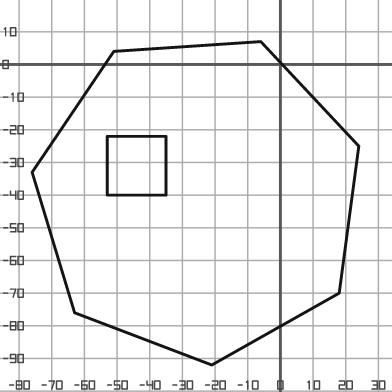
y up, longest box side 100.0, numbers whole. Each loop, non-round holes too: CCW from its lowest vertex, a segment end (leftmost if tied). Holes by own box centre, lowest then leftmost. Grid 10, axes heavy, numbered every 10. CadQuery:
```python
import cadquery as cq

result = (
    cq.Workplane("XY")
    .moveTo(-21.0, -92.0)
    .lineTo(18.0, -70.0)
    .lineTo(24.0, -25.0)
    .lineTo(-6.0, 7.0)
    .lineTo(-51.0, 4.0)
    .lineTo(-76.0, -33.0)
    .lineTo(-63.0, -76.0)
    .close()
    .moveTo(-53.0, -40.0)
    .lineTo(-35.0, -40.0)
    .lineTo(-35.0, -22.0)
    .lineTo(-53.0, -22.0)
    .close()
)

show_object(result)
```